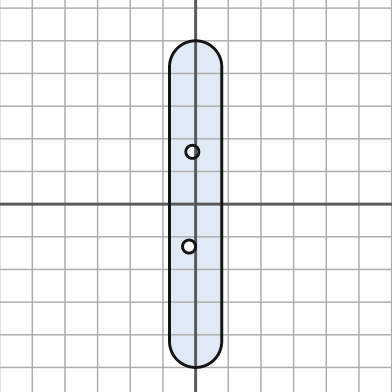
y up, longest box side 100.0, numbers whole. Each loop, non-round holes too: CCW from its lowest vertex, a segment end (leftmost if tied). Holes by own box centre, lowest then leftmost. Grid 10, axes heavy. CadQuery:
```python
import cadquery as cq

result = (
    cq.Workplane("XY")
    .moveTo(-8.0, -42.0)
    .threePointArc((0.0, -50.0), (8.0, -42.0))
    .lineTo(8.0, 42.0)
    .threePointArc((0.0, 50.0), (-8.0, 42.0))
    .close()
    .moveTo(-2.0, -13.0)
    .circle(2.0)
    .moveTo(-1.0, 16.0)
    .circle(2.0)
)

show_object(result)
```